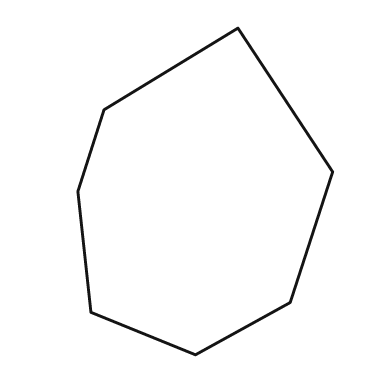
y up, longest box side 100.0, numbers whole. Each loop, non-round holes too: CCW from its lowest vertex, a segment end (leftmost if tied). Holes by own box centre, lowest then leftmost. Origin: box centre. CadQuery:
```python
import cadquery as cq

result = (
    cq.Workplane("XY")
    .moveTo(-3.0, -50.0)
    .lineTo(26.0, -34.0)
    .lineTo(39.0, 6.0)
    .lineTo(10.0, 50.0)
    .lineTo(-31.0, 25.0)
    .lineTo(-39.0, 0.0)
    .lineTo(-35.0, -37.0)
    .close()
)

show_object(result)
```